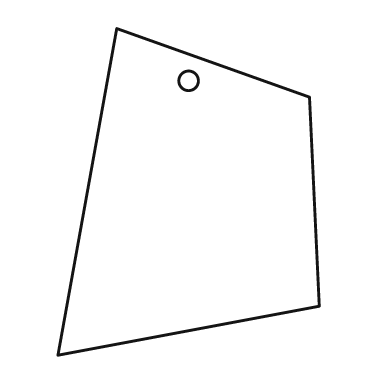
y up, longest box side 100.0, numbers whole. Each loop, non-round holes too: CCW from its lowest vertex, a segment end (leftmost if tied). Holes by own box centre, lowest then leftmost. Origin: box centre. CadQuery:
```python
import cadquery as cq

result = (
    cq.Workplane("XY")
    .moveTo(-40.0, -50.0)
    .lineTo(40.0, -35.0)
    .lineTo(37.0, 29.0)
    .lineTo(-22.0, 50.0)
    .close()
    .moveTo(0.0, 34.0)
    .circle(3.0)
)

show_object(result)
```